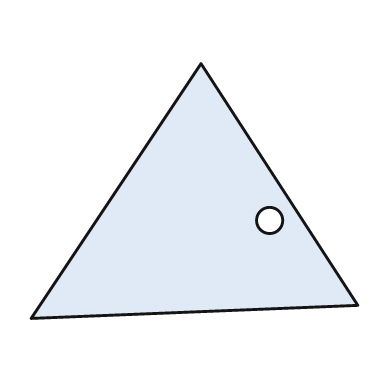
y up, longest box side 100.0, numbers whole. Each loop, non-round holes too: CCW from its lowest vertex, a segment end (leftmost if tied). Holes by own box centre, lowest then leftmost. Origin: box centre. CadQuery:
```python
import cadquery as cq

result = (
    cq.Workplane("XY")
    .moveTo(-50.0, -39.0)
    .lineTo(50.0, -35.0)
    .lineTo(2.0, 39.0)
    .close()
    .moveTo(23.0, -9.0)
    .circle(4.0)
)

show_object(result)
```